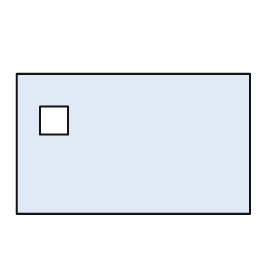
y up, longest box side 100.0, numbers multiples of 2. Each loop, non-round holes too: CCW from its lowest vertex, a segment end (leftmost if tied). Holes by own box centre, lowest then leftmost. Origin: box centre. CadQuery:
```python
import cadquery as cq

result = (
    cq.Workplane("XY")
    .moveTo(-50.0, -30.0)
    .lineTo(50.0, -30.0)
    .lineTo(50.0, 30.0)
    .lineTo(-50.0, 30.0)
    .close()
    .moveTo(-40.0, 4.0)
    .lineTo(-28.0, 4.0)
    .lineTo(-28.0, 16.0)
    .lineTo(-40.0, 16.0)
    .close()
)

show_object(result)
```